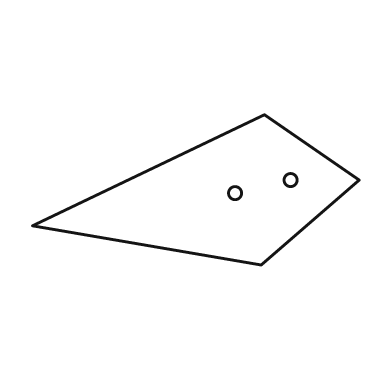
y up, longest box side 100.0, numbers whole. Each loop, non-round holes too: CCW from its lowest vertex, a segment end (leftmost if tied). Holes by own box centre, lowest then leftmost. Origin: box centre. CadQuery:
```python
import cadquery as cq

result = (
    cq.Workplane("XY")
    .moveTo(20.0, -23.0)
    .lineTo(50.0, 3.0)
    .lineTo(21.0, 23.0)
    .lineTo(-50.0, -11.0)
    .close()
    .moveTo(12.0, -1.0)
    .circle(2.0)
    .moveTo(29.0, 3.0)
    .circle(2.0)
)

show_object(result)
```